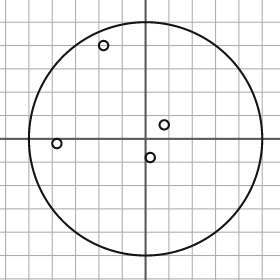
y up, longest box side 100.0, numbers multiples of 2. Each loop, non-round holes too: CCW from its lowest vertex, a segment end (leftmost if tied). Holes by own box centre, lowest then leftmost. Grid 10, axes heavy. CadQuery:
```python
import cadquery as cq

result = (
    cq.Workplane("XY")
    .moveTo(0.0, 0.0)
    .circle(50.0)
    .moveTo(2.0, -8.0)
    .circle(2.0)
    .moveTo(-38.0, -2.0)
    .circle(2.0)
    .moveTo(8.0, 6.0)
    .circle(2.0)
    .moveTo(-18.0, 40.0)
    .circle(2.0)
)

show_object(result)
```